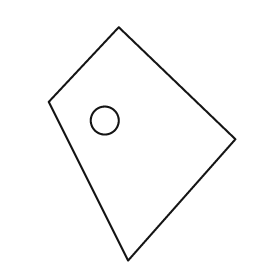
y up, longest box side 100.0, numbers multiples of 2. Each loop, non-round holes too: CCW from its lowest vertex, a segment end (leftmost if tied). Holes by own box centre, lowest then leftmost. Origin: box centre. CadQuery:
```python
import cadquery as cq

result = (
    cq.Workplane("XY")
    .moveTo(-6.0, -50.0)
    .lineTo(40.0, 2.0)
    .lineTo(-10.0, 50.0)
    .lineTo(-40.0, 18.0)
    .close()
    .moveTo(-16.0, 10.0)
    .circle(6.0)
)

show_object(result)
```